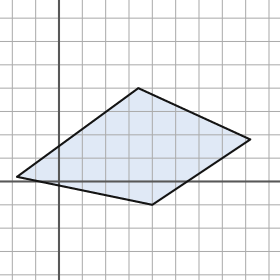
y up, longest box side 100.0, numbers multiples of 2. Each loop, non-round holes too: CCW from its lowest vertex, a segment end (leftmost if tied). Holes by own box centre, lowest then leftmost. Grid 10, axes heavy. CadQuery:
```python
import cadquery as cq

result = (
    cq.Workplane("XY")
    .moveTo(40.0, -10.0)
    .lineTo(82.0, 18.0)
    .lineTo(34.0, 40.0)
    .lineTo(-18.0, 2.0)
    .close()
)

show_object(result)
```